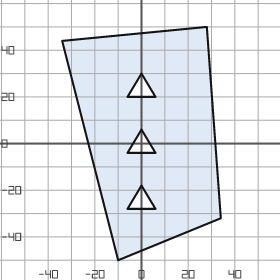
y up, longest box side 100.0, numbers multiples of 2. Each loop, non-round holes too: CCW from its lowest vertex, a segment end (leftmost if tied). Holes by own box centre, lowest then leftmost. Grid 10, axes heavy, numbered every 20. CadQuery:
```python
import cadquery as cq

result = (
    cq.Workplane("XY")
    .moveTo(-10.0, -50.0)
    .lineTo(34.0, -32.0)
    .lineTo(28.0, 50.0)
    .lineTo(-34.0, 44.0)
    .close()
    .moveTo(-6.0, -28.0)
    .lineTo(6.0, -28.0)
    .lineTo(0.0, -18.0)
    .close()
    .moveTo(-6.0, -4.0)
    .lineTo(6.0, -4.0)
    .lineTo(0.0, 6.0)
    .close()
    .moveTo(-6.0, 20.0)
    .lineTo(6.0, 20.0)
    .lineTo(0.0, 30.0)
    .close()
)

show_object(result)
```